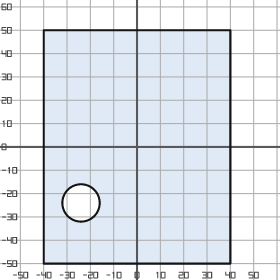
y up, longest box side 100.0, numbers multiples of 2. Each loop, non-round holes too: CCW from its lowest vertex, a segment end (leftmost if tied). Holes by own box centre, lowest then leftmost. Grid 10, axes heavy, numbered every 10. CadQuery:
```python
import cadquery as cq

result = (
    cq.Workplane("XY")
    .moveTo(-40.0, -50.0)
    .lineTo(40.0, -50.0)
    .lineTo(40.0, 50.0)
    .lineTo(-40.0, 50.0)
    .close()
    .moveTo(-24.0, -24.0)
    .circle(8.0)
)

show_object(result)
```